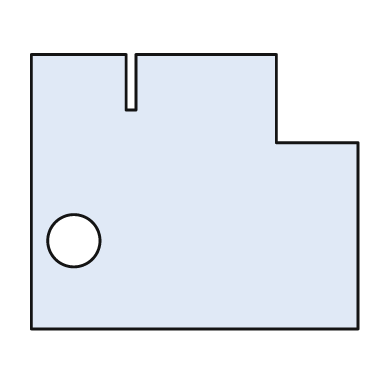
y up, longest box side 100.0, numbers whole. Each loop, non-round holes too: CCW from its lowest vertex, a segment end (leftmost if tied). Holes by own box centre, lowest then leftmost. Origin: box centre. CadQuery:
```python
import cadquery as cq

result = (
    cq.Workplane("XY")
    .moveTo(-50.0, -42.0)
    .lineTo(50.0, -42.0)
    .lineTo(50.0, 15.0)
    .lineTo(25.0, 15.0)
    .lineTo(25.0, 42.0)
    .lineTo(-18.0, 42.0)
    .lineTo(-18.0, 25.0)
    .lineTo(-21.0, 25.0)
    .lineTo(-21.0, 42.0)
    .lineTo(-50.0, 42.0)
    .close()
    .moveTo(-37.0, -15.0)
    .circle(8.0)
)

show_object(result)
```